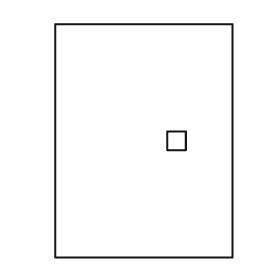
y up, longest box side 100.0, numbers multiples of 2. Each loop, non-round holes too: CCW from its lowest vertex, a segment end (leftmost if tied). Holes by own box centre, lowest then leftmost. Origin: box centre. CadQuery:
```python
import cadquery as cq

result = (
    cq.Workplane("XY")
    .moveTo(-38.0, -50.0)
    .lineTo(38.0, -50.0)
    .lineTo(38.0, 50.0)
    .lineTo(-38.0, 50.0)
    .close()
    .moveTo(10.0, -4.0)
    .lineTo(18.0, -4.0)
    .lineTo(18.0, 4.0)
    .lineTo(10.0, 4.0)
    .close()
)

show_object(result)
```